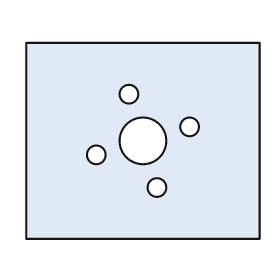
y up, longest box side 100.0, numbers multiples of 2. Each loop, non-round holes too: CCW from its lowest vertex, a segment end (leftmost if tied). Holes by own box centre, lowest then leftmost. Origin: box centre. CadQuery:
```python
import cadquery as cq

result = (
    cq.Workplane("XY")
    .moveTo(-50.0, -42.0)
    .lineTo(50.0, -42.0)
    .lineTo(50.0, 42.0)
    .lineTo(-50.0, 42.0)
    .close()
    .moveTo(6.0, -20.0)
    .circle(4.0)
    .moveTo(-20.0, -6.0)
    .circle(4.0)
    .moveTo(0.0, 0.0)
    .circle(10.0)
    .moveTo(20.0, 6.0)
    .circle(4.0)
    .moveTo(-6.0, 20.0)
    .circle(4.0)
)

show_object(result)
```